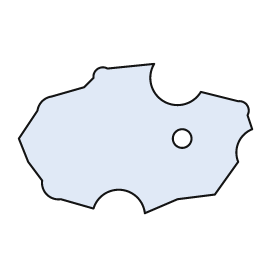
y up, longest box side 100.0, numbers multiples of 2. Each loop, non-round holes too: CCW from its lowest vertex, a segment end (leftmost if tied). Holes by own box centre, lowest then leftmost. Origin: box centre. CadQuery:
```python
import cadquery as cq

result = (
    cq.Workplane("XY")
    .moveTo(4.0, -32.0)
    .lineTo(18.0, -26.0)
    .lineTo(34.0, -24.0)
    .lineTo(44.0, -10.0)
    .threePointArc((44.0, -2.0), (50.0, 4.0))
    .lineTo(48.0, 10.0)
    .threePointArc((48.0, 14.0), (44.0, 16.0))
    .lineTo(28.0, 20.0)
    .threePointArc((12.0, 16.0), (8.0, 32.0))
    .lineTo(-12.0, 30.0)
    .threePointArc((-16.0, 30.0), (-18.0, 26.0))
    .lineTo(-22.0, 22.0)
    .lineTo(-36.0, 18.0)
    .threePointArc((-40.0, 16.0), (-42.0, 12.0))
    .lineTo(-50.0, 0.0)
    .lineTo(-46.0, -10.0)
    .lineTo(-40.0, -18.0)
    .threePointArc((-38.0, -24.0), (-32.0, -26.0))
    .lineTo(-18.0, -30.0)
    .threePointArc((-6.0, -22.0), (4.0, -32.0))
    .close()
    .moveTo(20.0, 0.0)
    .circle(4.0)
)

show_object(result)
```